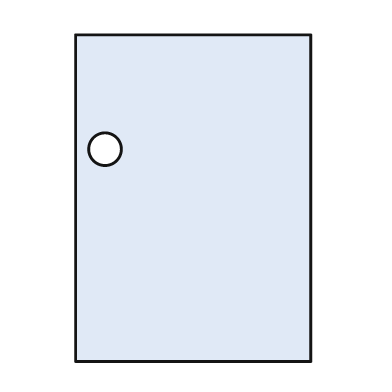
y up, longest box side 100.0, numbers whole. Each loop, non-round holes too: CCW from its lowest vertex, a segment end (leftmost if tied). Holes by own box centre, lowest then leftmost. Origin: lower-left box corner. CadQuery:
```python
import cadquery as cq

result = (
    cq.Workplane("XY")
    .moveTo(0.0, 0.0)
    .lineTo(72.0, 0.0)
    .lineTo(72.0, 100.0)
    .lineTo(0.0, 100.0)
    .close()
    .moveTo(9.0, 65.0)
    .circle(5.0)
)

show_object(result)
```